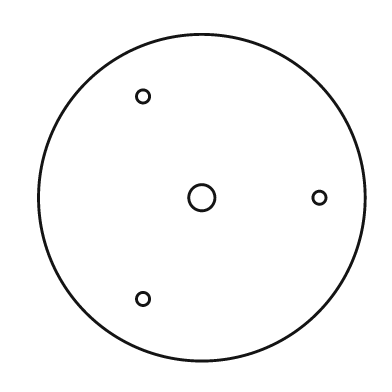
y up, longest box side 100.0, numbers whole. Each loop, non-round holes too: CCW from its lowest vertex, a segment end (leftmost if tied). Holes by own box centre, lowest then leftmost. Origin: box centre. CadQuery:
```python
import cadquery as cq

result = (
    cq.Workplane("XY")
    .moveTo(0.0, 0.0)
    .circle(50.0)
    .moveTo(-18.0, -31.0)
    .circle(2.0)
    .moveTo(0.0, 0.0)
    .circle(4.0)
    .moveTo(36.0, 0.0)
    .circle(2.0)
    .moveTo(-18.0, 31.0)
    .circle(2.0)
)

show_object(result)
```